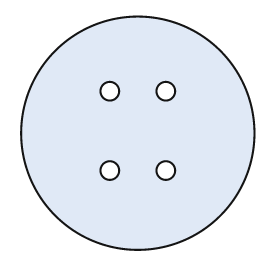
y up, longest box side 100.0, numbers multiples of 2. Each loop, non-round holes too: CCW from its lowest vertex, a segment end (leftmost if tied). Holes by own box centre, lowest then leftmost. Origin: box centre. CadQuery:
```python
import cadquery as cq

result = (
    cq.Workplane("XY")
    .moveTo(0.0, 0.0)
    .circle(50.0)
    .moveTo(-12.0, -16.0)
    .circle(4.0)
    .moveTo(12.0, -16.0)
    .circle(4.0)
    .moveTo(-12.0, 18.0)
    .circle(4.0)
    .moveTo(12.0, 18.0)
    .circle(4.0)
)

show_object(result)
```